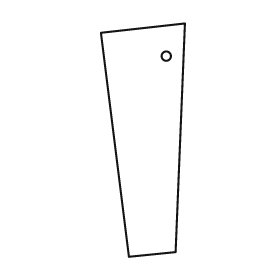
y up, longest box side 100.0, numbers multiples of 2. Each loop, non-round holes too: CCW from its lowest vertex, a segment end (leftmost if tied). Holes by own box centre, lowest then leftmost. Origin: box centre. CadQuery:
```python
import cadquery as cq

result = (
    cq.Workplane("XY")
    .moveTo(-6.0, -50.0)
    .lineTo(14.0, -48.0)
    .lineTo(18.0, 50.0)
    .lineTo(-18.0, 46.0)
    .close()
    .moveTo(10.0, 36.0)
    .circle(2.0)
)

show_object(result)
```